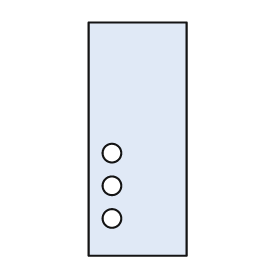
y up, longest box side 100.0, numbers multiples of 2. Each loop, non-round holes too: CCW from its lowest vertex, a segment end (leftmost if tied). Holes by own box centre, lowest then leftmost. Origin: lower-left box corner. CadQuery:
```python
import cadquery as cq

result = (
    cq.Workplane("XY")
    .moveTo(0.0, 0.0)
    .lineTo(42.0, 0.0)
    .lineTo(42.0, 100.0)
    .lineTo(0.0, 100.0)
    .close()
    .moveTo(10.0, 16.0)
    .circle(4.0)
    .moveTo(10.0, 30.0)
    .circle(4.0)
    .moveTo(10.0, 44.0)
    .circle(4.0)
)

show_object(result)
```